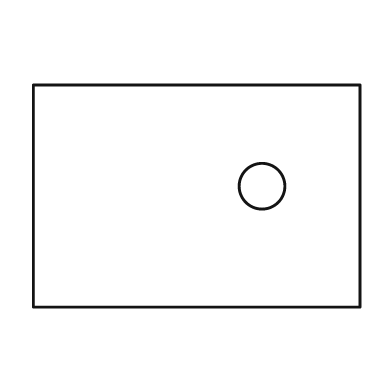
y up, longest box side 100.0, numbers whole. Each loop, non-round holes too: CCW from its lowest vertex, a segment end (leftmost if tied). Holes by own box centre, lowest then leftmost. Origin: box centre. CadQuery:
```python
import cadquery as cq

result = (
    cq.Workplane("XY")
    .moveTo(-50.0, -34.0)
    .lineTo(50.0, -34.0)
    .lineTo(50.0, 34.0)
    .lineTo(-50.0, 34.0)
    .close()
    .moveTo(20.0, 3.0)
    .circle(7.0)
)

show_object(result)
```